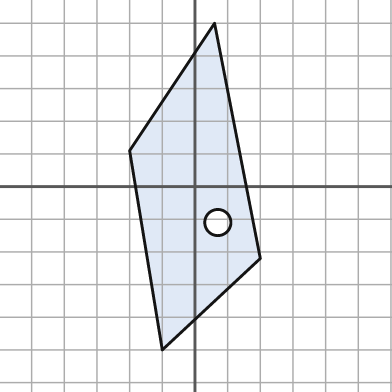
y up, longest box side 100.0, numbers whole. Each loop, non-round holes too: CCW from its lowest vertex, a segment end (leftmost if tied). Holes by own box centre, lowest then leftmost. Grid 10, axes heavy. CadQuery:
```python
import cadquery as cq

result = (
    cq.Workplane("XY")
    .moveTo(-10.0, -50.0)
    .lineTo(20.0, -22.0)
    .lineTo(6.0, 50.0)
    .lineTo(-20.0, 11.0)
    .close()
    .moveTo(7.0, -11.0)
    .circle(4.0)
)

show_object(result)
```